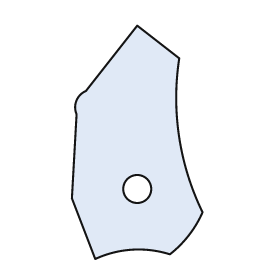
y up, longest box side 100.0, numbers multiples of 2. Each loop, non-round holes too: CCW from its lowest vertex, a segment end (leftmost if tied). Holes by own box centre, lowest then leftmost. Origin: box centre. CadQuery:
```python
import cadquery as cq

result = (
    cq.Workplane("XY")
    .moveTo(-18.0, -50.0)
    .threePointArc((-2.0, -46.0), (14.0, -48.0))
    .threePointArc((22.0, -40.0), (28.0, -30.0))
    .threePointArc((18.0, 2.0), (18.0, 36.0))
    .lineTo(0.0, 50.0)
    .lineTo(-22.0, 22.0)
    .threePointArc((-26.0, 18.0), (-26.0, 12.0))
    .lineTo(-28.0, -24.0)
    .close()
    .moveTo(0.0, -20.0)
    .circle(6.0)
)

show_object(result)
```